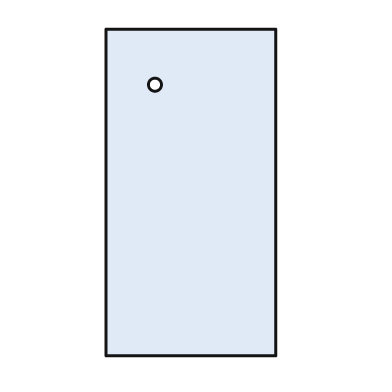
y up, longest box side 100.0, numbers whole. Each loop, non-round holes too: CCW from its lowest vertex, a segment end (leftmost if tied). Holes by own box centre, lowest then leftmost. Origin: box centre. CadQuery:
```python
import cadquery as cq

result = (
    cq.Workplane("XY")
    .moveTo(-26.0, -50.0)
    .lineTo(26.0, -50.0)
    .lineTo(26.0, 50.0)
    .lineTo(-26.0, 50.0)
    .close()
    .moveTo(-11.0, 33.0)
    .circle(2.0)
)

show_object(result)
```